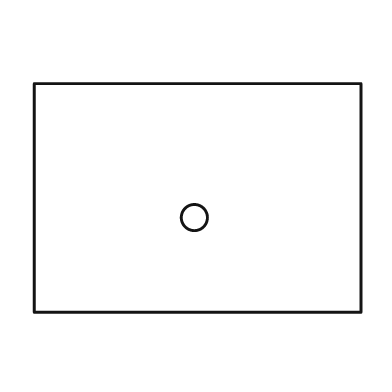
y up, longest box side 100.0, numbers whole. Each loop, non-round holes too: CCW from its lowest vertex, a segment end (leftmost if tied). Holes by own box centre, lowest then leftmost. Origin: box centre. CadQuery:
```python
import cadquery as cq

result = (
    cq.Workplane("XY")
    .moveTo(-50.0, -35.0)
    .lineTo(50.0, -35.0)
    .lineTo(50.0, 35.0)
    .lineTo(-50.0, 35.0)
    .close()
    .moveTo(-1.0, -6.0)
    .circle(4.0)
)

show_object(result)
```